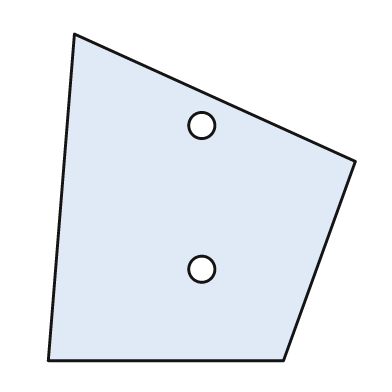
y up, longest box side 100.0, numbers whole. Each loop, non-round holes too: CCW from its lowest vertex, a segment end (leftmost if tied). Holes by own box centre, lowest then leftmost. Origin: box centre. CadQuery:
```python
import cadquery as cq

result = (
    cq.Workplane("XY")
    .moveTo(-47.0, -50.0)
    .lineTo(25.0, -50.0)
    .lineTo(47.0, 11.0)
    .lineTo(-39.0, 50.0)
    .close()
    .moveTo(0.0, -22.0)
    .circle(4.0)
    .moveTo(0.0, 22.0)
    .circle(4.0)
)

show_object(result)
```